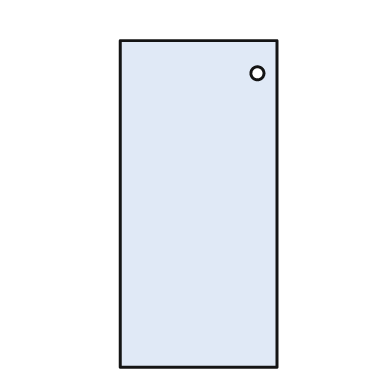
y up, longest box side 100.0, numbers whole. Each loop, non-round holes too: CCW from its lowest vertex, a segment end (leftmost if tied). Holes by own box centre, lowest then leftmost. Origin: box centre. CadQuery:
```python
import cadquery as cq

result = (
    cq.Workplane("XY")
    .moveTo(-24.0, -50.0)
    .lineTo(24.0, -50.0)
    .lineTo(24.0, 50.0)
    .lineTo(-24.0, 50.0)
    .close()
    .moveTo(18.0, 40.0)
    .circle(2.0)
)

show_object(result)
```